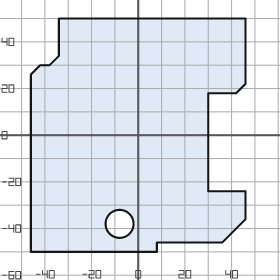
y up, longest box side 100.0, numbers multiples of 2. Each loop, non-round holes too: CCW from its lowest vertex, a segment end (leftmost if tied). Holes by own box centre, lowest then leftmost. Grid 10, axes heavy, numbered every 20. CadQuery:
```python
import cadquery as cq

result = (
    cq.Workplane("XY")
    .moveTo(-46.0, -50.0)
    .lineTo(8.0, -50.0)
    .lineTo(8.0, -46.0)
    .lineTo(36.0, -46.0)
    .lineTo(46.0, -36.0)
    .lineTo(46.0, -24.0)
    .lineTo(30.0, -24.0)
    .lineTo(30.0, 18.0)
    .lineTo(42.0, 18.0)
    .lineTo(46.0, 22.0)
    .lineTo(46.0, 50.0)
    .lineTo(-34.0, 50.0)
    .lineTo(-34.0, 34.0)
    .lineTo(-38.0, 30.0)
    .lineTo(-42.0, 30.0)
    .lineTo(-46.0, 26.0)
    .close()
    .moveTo(-8.0, -38.0)
    .circle(6.0)
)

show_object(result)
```